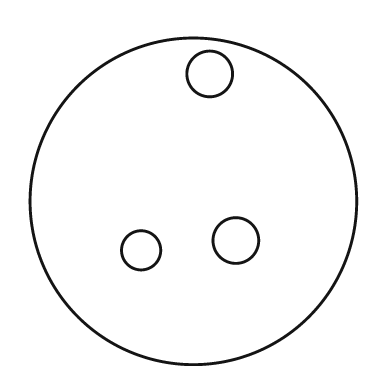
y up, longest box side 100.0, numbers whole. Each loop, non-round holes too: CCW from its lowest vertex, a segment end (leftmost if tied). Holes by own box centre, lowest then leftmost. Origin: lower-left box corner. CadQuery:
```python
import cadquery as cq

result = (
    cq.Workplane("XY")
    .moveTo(50.0, 50.0)
    .circle(50.0)
    .moveTo(34.0, 35.0)
    .circle(6.0)
    .moveTo(63.0, 38.0)
    .circle(7.0)
    .moveTo(55.0, 89.0)
    .circle(7.0)
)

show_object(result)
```